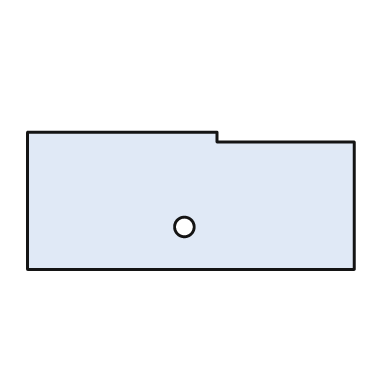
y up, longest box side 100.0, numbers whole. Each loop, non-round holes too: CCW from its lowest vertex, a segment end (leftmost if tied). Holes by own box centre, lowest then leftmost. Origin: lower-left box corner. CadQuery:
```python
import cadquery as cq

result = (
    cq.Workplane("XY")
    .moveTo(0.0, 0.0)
    .lineTo(100.0, 0.0)
    .lineTo(100.0, 39.0)
    .lineTo(58.0, 39.0)
    .lineTo(58.0, 42.0)
    .lineTo(0.0, 42.0)
    .close()
    .moveTo(48.0, 13.0)
    .circle(3.0)
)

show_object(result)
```